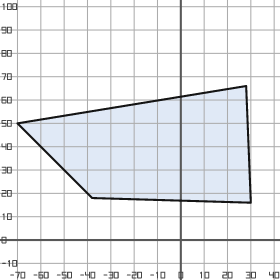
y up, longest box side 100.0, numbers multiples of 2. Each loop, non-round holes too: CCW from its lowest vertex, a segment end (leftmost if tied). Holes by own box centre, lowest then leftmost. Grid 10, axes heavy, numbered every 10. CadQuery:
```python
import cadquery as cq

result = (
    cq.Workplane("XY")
    .moveTo(30.0, 16.0)
    .lineTo(28.0, 66.0)
    .lineTo(-70.0, 50.0)
    .lineTo(-38.0, 18.0)
    .close()
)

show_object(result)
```